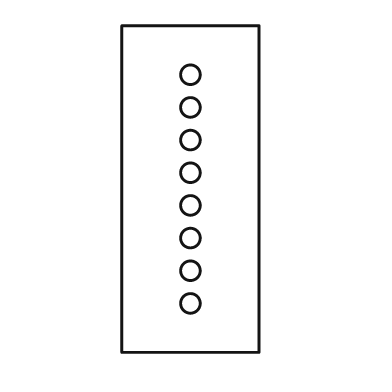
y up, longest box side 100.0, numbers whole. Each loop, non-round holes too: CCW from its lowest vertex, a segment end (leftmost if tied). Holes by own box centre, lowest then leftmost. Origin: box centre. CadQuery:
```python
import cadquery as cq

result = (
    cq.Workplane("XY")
    .moveTo(-21.0, -50.0)
    .lineTo(21.0, -50.0)
    .lineTo(21.0, 50.0)
    .lineTo(-21.0, 50.0)
    .close()
    .moveTo(0.0, -35.0)
    .circle(3.0)
    .moveTo(0.0, -25.0)
    .circle(3.0)
    .moveTo(0.0, -15.0)
    .circle(3.0)
    .moveTo(0.0, -5.0)
    .circle(3.0)
    .moveTo(0.0, 5.0)
    .circle(3.0)
    .moveTo(0.0, 15.0)
    .circle(3.0)
    .moveTo(0.0, 25.0)
    .circle(3.0)
    .moveTo(0.0, 35.0)
    .circle(3.0)
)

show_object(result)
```